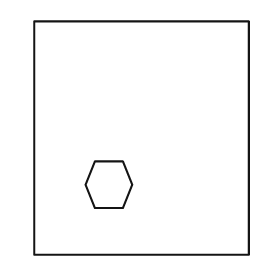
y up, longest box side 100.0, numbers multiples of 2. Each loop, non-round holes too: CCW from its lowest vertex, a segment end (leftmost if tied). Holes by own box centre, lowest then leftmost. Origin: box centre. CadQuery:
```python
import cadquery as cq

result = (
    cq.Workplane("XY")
    .moveTo(-46.0, -50.0)
    .lineTo(46.0, -50.0)
    .lineTo(46.0, 50.0)
    .lineTo(-46.0, 50.0)
    .close()
    .moveTo(-20.0, -30.0)
    .lineTo(-8.0, -30.0)
    .lineTo(-4.0, -20.0)
    .lineTo(-8.0, -10.0)
    .lineTo(-20.0, -10.0)
    .lineTo(-24.0, -20.0)
    .close()
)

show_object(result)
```